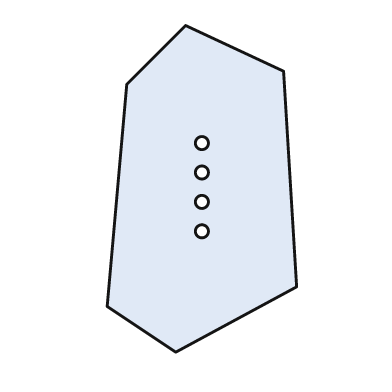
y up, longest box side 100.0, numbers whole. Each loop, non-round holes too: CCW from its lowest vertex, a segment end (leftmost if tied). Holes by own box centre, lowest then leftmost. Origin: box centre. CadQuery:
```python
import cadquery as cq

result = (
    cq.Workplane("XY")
    .moveTo(-8.0, -50.0)
    .lineTo(29.0, -30.0)
    .lineTo(25.0, 36.0)
    .lineTo(-5.0, 50.0)
    .lineTo(-23.0, 32.0)
    .lineTo(-29.0, -36.0)
    .close()
    .moveTo(0.0, -13.0)
    .circle(2.0)
    .moveTo(0.0, -4.0)
    .circle(2.0)
    .moveTo(0.0, 5.0)
    .circle(2.0)
    .moveTo(0.0, 14.0)
    .circle(2.0)
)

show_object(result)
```